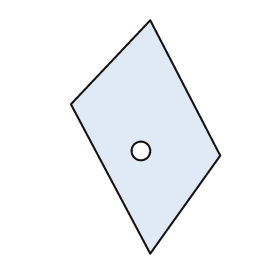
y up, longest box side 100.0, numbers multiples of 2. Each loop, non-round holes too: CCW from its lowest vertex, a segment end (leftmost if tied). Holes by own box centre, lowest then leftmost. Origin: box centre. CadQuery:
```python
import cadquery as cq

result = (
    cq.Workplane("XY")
    .moveTo(2.0, -50.0)
    .lineTo(32.0, -8.0)
    .lineTo(2.0, 50.0)
    .lineTo(-32.0, 14.0)
    .close()
    .moveTo(-2.0, -6.0)
    .circle(4.0)
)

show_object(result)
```